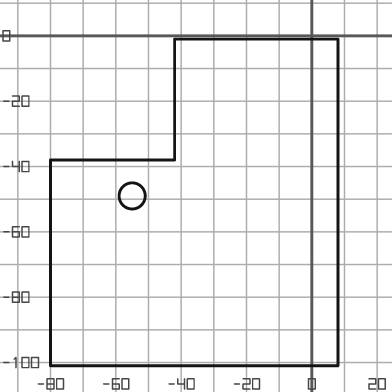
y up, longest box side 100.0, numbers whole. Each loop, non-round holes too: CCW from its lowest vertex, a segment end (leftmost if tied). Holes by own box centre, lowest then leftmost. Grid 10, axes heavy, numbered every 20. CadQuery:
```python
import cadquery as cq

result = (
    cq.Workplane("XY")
    .moveTo(-80.0, -101.0)
    .lineTo(8.0, -101.0)
    .lineTo(8.0, -1.0)
    .lineTo(-42.0, -1.0)
    .lineTo(-42.0, -38.0)
    .lineTo(-80.0, -38.0)
    .close()
    .moveTo(-55.0, -49.0)
    .circle(4.0)
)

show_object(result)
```